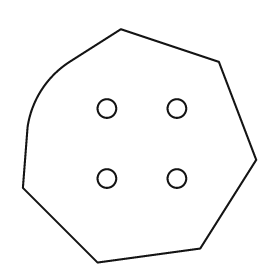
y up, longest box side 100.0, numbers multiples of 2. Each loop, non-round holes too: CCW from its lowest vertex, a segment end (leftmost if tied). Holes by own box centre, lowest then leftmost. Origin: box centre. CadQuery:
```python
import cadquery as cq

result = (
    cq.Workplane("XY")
    .moveTo(-18.0, -50.0)
    .lineTo(26.0, -44.0)
    .lineTo(50.0, -6.0)
    .lineTo(34.0, 36.0)
    .lineTo(-8.0, 50.0)
    .lineTo(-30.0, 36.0)
    .threePointArc((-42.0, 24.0), (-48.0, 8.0))
    .lineTo(-50.0, -18.0)
    .close()
    .moveTo(-14.0, -14.0)
    .circle(4.0)
    .moveTo(16.0, -14.0)
    .circle(4.0)
    .moveTo(-14.0, 16.0)
    .circle(4.0)
    .moveTo(16.0, 16.0)
    .circle(4.0)
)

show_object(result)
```